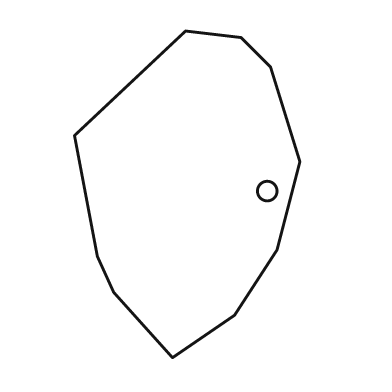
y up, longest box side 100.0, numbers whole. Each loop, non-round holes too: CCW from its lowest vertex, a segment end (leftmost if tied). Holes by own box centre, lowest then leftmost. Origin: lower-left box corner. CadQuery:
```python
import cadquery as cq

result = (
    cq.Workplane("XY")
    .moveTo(30.0, 0.0)
    .lineTo(49.0, 13.0)
    .lineTo(62.0, 33.0)
    .lineTo(69.0, 60.0)
    .lineTo(60.0, 89.0)
    .lineTo(51.0, 98.0)
    .lineTo(34.0, 100.0)
    .lineTo(0.0, 68.0)
    .lineTo(7.0, 31.0)
    .lineTo(12.0, 20.0)
    .close()
    .moveTo(59.0, 51.0)
    .circle(3.0)
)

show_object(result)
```